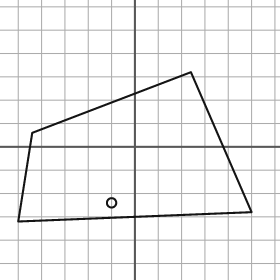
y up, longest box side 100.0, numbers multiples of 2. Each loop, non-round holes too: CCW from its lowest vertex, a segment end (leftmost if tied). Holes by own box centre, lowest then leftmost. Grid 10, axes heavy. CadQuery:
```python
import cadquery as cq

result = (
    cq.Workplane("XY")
    .moveTo(-50.0, -32.0)
    .lineTo(50.0, -28.0)
    .lineTo(24.0, 32.0)
    .lineTo(-44.0, 6.0)
    .close()
    .moveTo(-10.0, -24.0)
    .circle(2.0)
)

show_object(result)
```